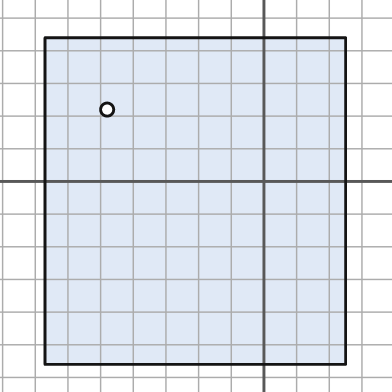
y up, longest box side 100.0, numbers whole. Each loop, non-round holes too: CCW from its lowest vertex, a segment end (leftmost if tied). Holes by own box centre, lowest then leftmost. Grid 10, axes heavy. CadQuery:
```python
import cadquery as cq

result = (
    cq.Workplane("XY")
    .moveTo(-67.0, -56.0)
    .lineTo(25.0, -56.0)
    .lineTo(25.0, 44.0)
    .lineTo(-67.0, 44.0)
    .close()
    .moveTo(-48.0, 22.0)
    .circle(2.0)
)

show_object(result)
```